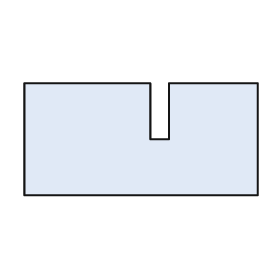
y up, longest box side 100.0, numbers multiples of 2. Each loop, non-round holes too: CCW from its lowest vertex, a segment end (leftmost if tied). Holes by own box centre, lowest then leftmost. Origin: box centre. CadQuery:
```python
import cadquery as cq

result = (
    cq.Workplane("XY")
    .moveTo(-50.0, -24.0)
    .lineTo(50.0, -24.0)
    .lineTo(50.0, 24.0)
    .lineTo(12.0, 24.0)
    .lineTo(12.0, 0.0)
    .lineTo(4.0, 0.0)
    .lineTo(4.0, 24.0)
    .lineTo(-50.0, 24.0)
    .close()
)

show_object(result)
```